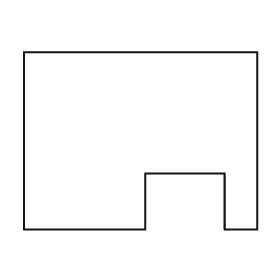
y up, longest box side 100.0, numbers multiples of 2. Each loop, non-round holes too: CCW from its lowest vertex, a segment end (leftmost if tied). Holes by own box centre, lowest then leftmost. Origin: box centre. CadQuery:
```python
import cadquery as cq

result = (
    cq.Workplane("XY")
    .moveTo(-50.0, -38.0)
    .lineTo(2.0, -38.0)
    .lineTo(2.0, -14.0)
    .lineTo(36.0, -14.0)
    .lineTo(36.0, -38.0)
    .lineTo(50.0, -38.0)
    .lineTo(50.0, 38.0)
    .lineTo(-50.0, 38.0)
    .close()
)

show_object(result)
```